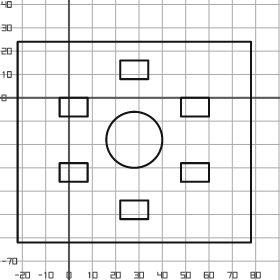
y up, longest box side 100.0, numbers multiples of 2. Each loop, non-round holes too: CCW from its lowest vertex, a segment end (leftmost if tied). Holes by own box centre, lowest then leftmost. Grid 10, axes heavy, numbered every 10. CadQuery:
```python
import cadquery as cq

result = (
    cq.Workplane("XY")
    .moveTo(-22.0, -62.0)
    .lineTo(78.0, -62.0)
    .lineTo(78.0, 24.0)
    .lineTo(-22.0, 24.0)
    .close()
    .moveTo(22.0, -52.0)
    .lineTo(34.0, -52.0)
    .lineTo(34.0, -44.0)
    .lineTo(22.0, -44.0)
    .close()
    .moveTo(-4.0, -36.0)
    .lineTo(8.0, -36.0)
    .lineTo(8.0, -28.0)
    .lineTo(-4.0, -28.0)
    .close()
    .moveTo(48.0, -36.0)
    .lineTo(60.0, -36.0)
    .lineTo(60.0, -28.0)
    .lineTo(48.0, -28.0)
    .close()
    .moveTo(28.0, -18.0)
    .circle(12.0)
    .moveTo(-4.0, -8.0)
    .lineTo(8.0, -8.0)
    .lineTo(8.0, 0.0)
    .lineTo(-4.0, 0.0)
    .close()
    .moveTo(48.0, -8.0)
    .lineTo(60.0, -8.0)
    .lineTo(60.0, 0.0)
    .lineTo(48.0, 0.0)
    .close()
    .moveTo(22.0, 8.0)
    .lineTo(34.0, 8.0)
    .lineTo(34.0, 16.0)
    .lineTo(22.0, 16.0)
    .close()
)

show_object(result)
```